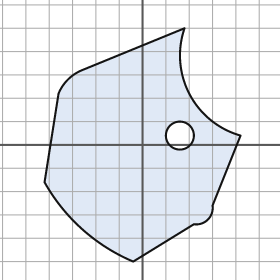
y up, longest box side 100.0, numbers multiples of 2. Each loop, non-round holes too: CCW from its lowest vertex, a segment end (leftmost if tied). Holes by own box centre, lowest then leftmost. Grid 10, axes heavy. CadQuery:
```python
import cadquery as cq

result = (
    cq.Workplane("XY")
    .moveTo(-4.0, -50.0)
    .lineTo(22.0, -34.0)
    .threePointArc((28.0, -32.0), (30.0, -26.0))
    .lineTo(42.0, 4.0)
    .threePointArc((20.0, 22.0), (18.0, 50.0))
    .lineTo(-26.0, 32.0)
    .threePointArc((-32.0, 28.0), (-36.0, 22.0))
    .lineTo(-42.0, -16.0)
    .threePointArc((-26.0, -36.0), (-4.0, -50.0))
    .close()
    .moveTo(16.0, 4.0)
    .circle(6.0)
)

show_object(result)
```